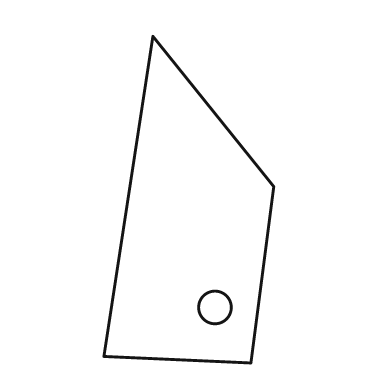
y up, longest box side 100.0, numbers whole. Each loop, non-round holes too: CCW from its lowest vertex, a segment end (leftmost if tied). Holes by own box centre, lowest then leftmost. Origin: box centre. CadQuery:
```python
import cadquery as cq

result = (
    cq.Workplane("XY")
    .moveTo(19.0, -50.0)
    .lineTo(26.0, 4.0)
    .lineTo(-11.0, 50.0)
    .lineTo(-26.0, -48.0)
    .close()
    .moveTo(8.0, -33.0)
    .circle(5.0)
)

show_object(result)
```